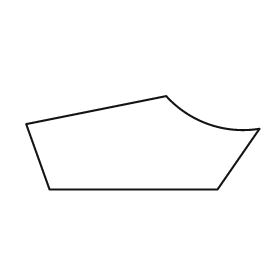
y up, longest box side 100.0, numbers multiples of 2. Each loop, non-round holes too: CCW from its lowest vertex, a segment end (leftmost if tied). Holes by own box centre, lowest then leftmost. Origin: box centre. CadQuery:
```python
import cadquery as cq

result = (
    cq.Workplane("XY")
    .moveTo(-40.0, -20.0)
    .lineTo(32.0, -20.0)
    .lineTo(50.0, 6.0)
    .threePointArc((28.0, 8.0), (10.0, 20.0))
    .lineTo(-50.0, 8.0)
    .close()
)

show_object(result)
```